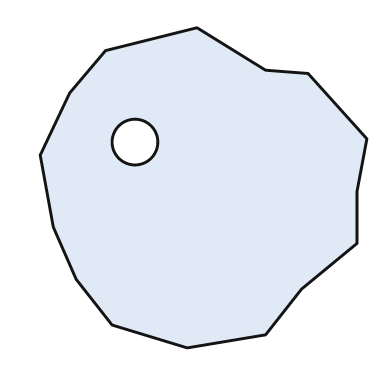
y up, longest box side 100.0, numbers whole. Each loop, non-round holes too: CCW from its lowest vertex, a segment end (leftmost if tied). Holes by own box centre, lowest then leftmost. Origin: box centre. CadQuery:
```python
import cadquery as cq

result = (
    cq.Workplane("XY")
    .moveTo(-5.0, -49.0)
    .lineTo(19.0, -45.0)
    .lineTo(30.0, -31.0)
    .lineTo(47.0, -17.0)
    .lineTo(47.0, -1.0)
    .lineTo(50.0, 15.0)
    .lineTo(32.0, 35.0)
    .lineTo(19.0, 36.0)
    .lineTo(-2.0, 49.0)
    .lineTo(-30.0, 42.0)
    .lineTo(-41.0, 29.0)
    .lineTo(-50.0, 10.0)
    .lineTo(-46.0, -12.0)
    .lineTo(-39.0, -28.0)
    .lineTo(-28.0, -42.0)
    .close()
    .moveTo(-21.0, 14.0)
    .circle(7.0)
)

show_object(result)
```